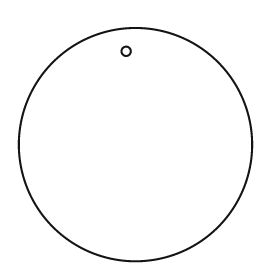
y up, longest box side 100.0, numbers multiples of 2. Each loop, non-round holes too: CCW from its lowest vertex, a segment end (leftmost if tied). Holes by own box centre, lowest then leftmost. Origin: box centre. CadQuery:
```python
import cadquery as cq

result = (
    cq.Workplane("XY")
    .moveTo(0.0, 0.0)
    .circle(50.0)
    .moveTo(-4.0, 40.0)
    .circle(2.0)
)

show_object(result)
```